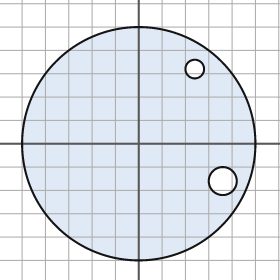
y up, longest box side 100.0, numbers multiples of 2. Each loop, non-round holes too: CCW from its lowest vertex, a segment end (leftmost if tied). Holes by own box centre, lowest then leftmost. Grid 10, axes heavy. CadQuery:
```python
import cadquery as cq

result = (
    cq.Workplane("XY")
    .moveTo(0.0, 0.0)
    .circle(50.0)
    .moveTo(36.0, -16.0)
    .circle(6.0)
    .moveTo(24.0, 32.0)
    .circle(4.0)
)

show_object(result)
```